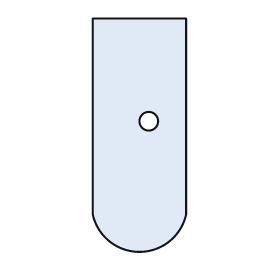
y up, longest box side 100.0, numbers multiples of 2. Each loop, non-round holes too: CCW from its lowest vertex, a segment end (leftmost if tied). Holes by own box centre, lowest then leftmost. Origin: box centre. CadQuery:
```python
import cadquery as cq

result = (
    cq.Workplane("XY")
    .moveTo(-20.0, -34.0)
    .threePointArc((0.0, -50.0), (20.0, -34.0))
    .lineTo(20.0, 50.0)
    .lineTo(-20.0, 50.0)
    .close()
    .moveTo(4.0, 6.0)
    .circle(4.0)
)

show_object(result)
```